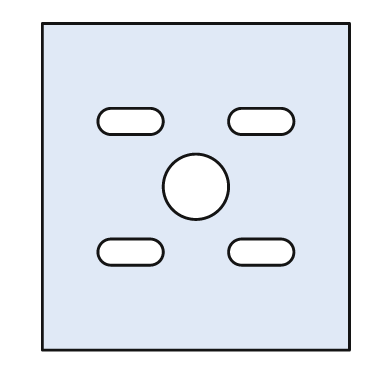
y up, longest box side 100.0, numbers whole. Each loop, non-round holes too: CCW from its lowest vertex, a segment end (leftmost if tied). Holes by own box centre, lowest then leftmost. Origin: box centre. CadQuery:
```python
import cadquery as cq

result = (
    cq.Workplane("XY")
    .moveTo(-47.0, -50.0)
    .lineTo(47.0, -50.0)
    .lineTo(47.0, 50.0)
    .lineTo(-47.0, 50.0)
    .close()
    .moveTo(-26.0, -24.0)
    .lineTo(-14.0, -24.0)
    .threePointArc((-10.0, -20.0), (-14.0, -16.0))
    .lineTo(-26.0, -16.0)
    .threePointArc((-30.0, -20.0), (-26.0, -24.0))
    .close()
    .moveTo(14.0, -24.0)
    .lineTo(26.0, -24.0)
    .threePointArc((30.0, -20.0), (26.0, -16.0))
    .lineTo(14.0, -16.0)
    .threePointArc((10.0, -20.0), (14.0, -24.0))
    .close()
    .moveTo(0.0, 0.0)
    .circle(10.0)
    .moveTo(-26.0, 16.0)
    .lineTo(-14.0, 16.0)
    .threePointArc((-10.0, 20.0), (-14.0, 24.0))
    .lineTo(-26.0, 24.0)
    .threePointArc((-30.0, 20.0), (-26.0, 16.0))
    .close()
    .moveTo(14.0, 16.0)
    .lineTo(26.0, 16.0)
    .threePointArc((30.0, 20.0), (26.0, 24.0))
    .lineTo(14.0, 24.0)
    .threePointArc((10.0, 20.0), (14.0, 16.0))
    .close()
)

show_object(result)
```